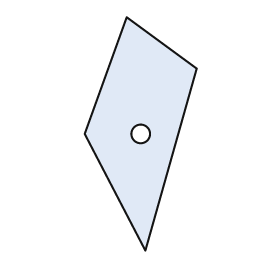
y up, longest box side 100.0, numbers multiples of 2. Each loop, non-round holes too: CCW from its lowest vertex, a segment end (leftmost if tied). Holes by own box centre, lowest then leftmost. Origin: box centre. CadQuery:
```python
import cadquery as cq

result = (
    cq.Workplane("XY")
    .moveTo(2.0, -50.0)
    .lineTo(24.0, 28.0)
    .lineTo(-6.0, 50.0)
    .lineTo(-24.0, 0.0)
    .close()
    .moveTo(0.0, 0.0)
    .circle(4.0)
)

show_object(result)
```